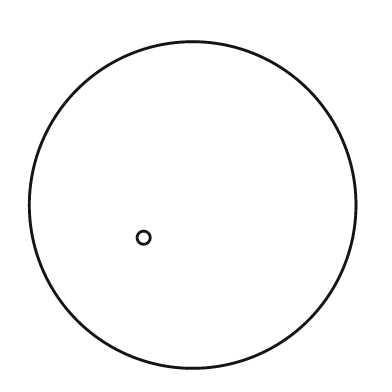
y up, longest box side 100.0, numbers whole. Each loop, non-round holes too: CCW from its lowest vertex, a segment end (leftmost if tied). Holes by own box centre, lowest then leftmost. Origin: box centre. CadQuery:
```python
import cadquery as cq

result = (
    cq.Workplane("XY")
    .moveTo(0.0, 0.0)
    .circle(50.0)
    .moveTo(-15.0, -10.0)
    .circle(2.0)
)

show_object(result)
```